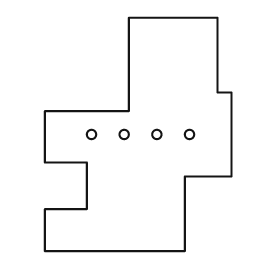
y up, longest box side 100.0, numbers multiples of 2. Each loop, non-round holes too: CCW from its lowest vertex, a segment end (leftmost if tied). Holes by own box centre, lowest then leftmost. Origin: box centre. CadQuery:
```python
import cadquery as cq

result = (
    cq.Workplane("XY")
    .moveTo(-40.0, -50.0)
    .lineTo(20.0, -50.0)
    .lineTo(20.0, -18.0)
    .lineTo(40.0, -18.0)
    .lineTo(40.0, 18.0)
    .lineTo(34.0, 18.0)
    .lineTo(34.0, 50.0)
    .lineTo(-4.0, 50.0)
    .lineTo(-4.0, 10.0)
    .lineTo(-40.0, 10.0)
    .lineTo(-40.0, -12.0)
    .lineTo(-22.0, -12.0)
    .lineTo(-22.0, -32.0)
    .lineTo(-40.0, -32.0)
    .close()
    .moveTo(-20.0, 0.0)
    .circle(2.0)
    .moveTo(-6.0, 0.0)
    .circle(2.0)
    .moveTo(8.0, 0.0)
    .circle(2.0)
    .moveTo(22.0, 0.0)
    .circle(2.0)
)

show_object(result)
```